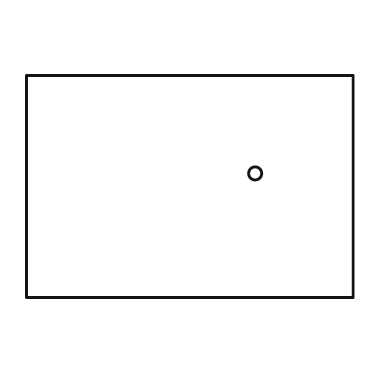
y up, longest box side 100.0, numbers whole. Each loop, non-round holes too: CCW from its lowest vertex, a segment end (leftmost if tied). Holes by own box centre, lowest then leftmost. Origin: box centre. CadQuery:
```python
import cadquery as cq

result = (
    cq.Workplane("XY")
    .moveTo(-50.0, -34.0)
    .lineTo(50.0, -34.0)
    .lineTo(50.0, 34.0)
    .lineTo(-50.0, 34.0)
    .close()
    .moveTo(20.0, 4.0)
    .circle(2.0)
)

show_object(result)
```